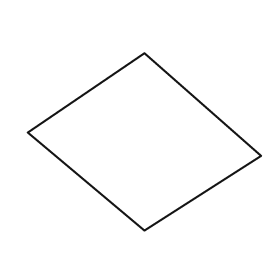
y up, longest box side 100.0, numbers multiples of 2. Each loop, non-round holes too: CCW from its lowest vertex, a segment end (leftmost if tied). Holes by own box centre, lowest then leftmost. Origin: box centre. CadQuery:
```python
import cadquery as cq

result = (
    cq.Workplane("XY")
    .moveTo(0.0, -38.0)
    .lineTo(50.0, -6.0)
    .lineTo(0.0, 38.0)
    .lineTo(-50.0, 4.0)
    .close()
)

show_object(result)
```